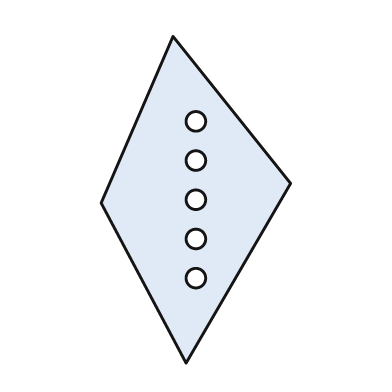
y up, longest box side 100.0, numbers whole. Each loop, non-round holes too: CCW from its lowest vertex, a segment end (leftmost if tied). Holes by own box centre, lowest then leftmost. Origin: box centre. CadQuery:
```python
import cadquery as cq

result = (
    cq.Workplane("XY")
    .moveTo(-3.0, -50.0)
    .lineTo(29.0, 5.0)
    .lineTo(-7.0, 50.0)
    .lineTo(-29.0, -1.0)
    .close()
    .moveTo(0.0, -24.0)
    .circle(3.0)
    .moveTo(0.0, -12.0)
    .circle(3.0)
    .moveTo(0.0, 0.0)
    .circle(3.0)
    .moveTo(0.0, 12.0)
    .circle(3.0)
    .moveTo(0.0, 24.0)
    .circle(3.0)
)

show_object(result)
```